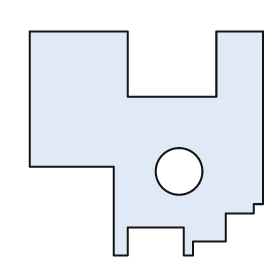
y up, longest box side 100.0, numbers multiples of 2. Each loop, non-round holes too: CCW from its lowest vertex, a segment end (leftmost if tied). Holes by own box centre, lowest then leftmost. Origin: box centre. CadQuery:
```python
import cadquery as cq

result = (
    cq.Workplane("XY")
    .moveTo(-14.0, -48.0)
    .lineTo(-8.0, -48.0)
    .lineTo(-8.0, -36.0)
    .lineTo(16.0, -36.0)
    .lineTo(16.0, -48.0)
    .lineTo(20.0, -48.0)
    .lineTo(20.0, -42.0)
    .lineTo(34.0, -42.0)
    .lineTo(34.0, -30.0)
    .lineTo(46.0, -30.0)
    .lineTo(46.0, -26.0)
    .lineTo(50.0, -26.0)
    .lineTo(50.0, 48.0)
    .lineTo(30.0, 48.0)
    .lineTo(30.0, 20.0)
    .lineTo(-8.0, 20.0)
    .lineTo(-8.0, 48.0)
    .lineTo(-50.0, 48.0)
    .lineTo(-50.0, -10.0)
    .lineTo(-14.0, -10.0)
    .close()
    .moveTo(14.0, -12.0)
    .circle(10.0)
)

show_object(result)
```